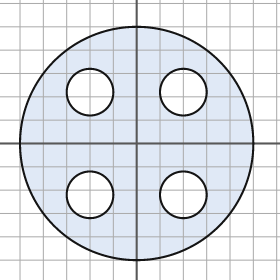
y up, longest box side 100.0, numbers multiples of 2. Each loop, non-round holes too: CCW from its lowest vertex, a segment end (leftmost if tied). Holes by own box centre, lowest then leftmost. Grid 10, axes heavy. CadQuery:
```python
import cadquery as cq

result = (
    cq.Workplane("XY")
    .moveTo(0.0, 0.0)
    .circle(50.0)
    .moveTo(-20.0, -22.0)
    .circle(10.0)
    .moveTo(20.0, -22.0)
    .circle(10.0)
    .moveTo(-20.0, 22.0)
    .circle(10.0)
    .moveTo(20.0, 22.0)
    .circle(10.0)
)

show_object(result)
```